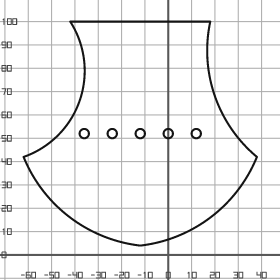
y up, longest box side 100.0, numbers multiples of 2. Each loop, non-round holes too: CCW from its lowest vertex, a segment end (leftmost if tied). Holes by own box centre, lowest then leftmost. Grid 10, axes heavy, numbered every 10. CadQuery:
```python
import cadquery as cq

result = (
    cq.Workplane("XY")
    .moveTo(-12.0, 4.0)
    .threePointArc((18.0, 16.0), (38.0, 42.0))
    .threePointArc((20.0, 68.0), (18.0, 100.0))
    .lineTo(-42.0, 100.0)
    .threePointArc((-38.0, 66.0), (-62.0, 42.0))
    .threePointArc((-42.0, 16.0), (-12.0, 4.0))
    .close()
    .moveTo(-36.0, 52.0)
    .circle(2.0)
    .moveTo(-24.0, 52.0)
    .circle(2.0)
    .moveTo(-12.0, 52.0)
    .circle(2.0)
    .moveTo(0.0, 52.0)
    .circle(2.0)
    .moveTo(12.0, 52.0)
    .circle(2.0)
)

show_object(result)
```